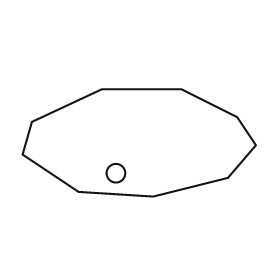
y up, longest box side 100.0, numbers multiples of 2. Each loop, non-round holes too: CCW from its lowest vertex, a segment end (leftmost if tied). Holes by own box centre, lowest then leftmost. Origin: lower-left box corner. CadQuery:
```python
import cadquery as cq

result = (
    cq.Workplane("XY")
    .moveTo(56.0, 0.0)
    .lineTo(88.0, 8.0)
    .lineTo(100.0, 22.0)
    .lineTo(92.0, 34.0)
    .lineTo(68.0, 46.0)
    .lineTo(34.0, 46.0)
    .lineTo(4.0, 32.0)
    .lineTo(0.0, 18.0)
    .lineTo(24.0, 2.0)
    .close()
    .moveTo(40.0, 10.0)
    .circle(4.0)
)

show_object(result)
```